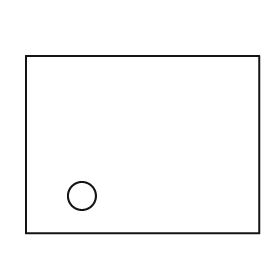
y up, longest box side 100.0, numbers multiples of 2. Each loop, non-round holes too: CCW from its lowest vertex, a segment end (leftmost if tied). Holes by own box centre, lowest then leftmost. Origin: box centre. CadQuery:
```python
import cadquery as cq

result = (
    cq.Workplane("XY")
    .moveTo(-50.0, -38.0)
    .lineTo(50.0, -38.0)
    .lineTo(50.0, 38.0)
    .lineTo(-50.0, 38.0)
    .close()
    .moveTo(-26.0, -22.0)
    .circle(6.0)
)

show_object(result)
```